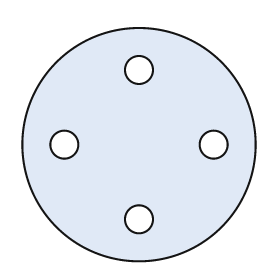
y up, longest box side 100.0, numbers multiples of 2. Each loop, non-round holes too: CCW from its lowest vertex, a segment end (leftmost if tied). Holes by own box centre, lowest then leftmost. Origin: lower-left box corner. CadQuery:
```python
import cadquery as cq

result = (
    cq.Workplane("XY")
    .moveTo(50.0, 50.0)
    .circle(50.0)
    .moveTo(50.0, 18.0)
    .circle(6.0)
    .moveTo(18.0, 50.0)
    .circle(6.0)
    .moveTo(82.0, 50.0)
    .circle(6.0)
    .moveTo(50.0, 82.0)
    .circle(6.0)
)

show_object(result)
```